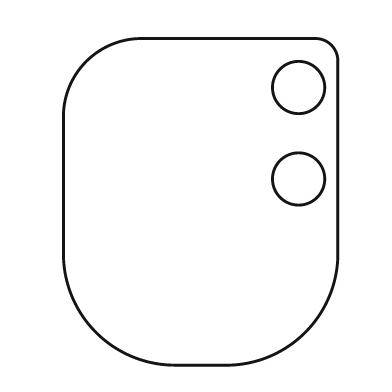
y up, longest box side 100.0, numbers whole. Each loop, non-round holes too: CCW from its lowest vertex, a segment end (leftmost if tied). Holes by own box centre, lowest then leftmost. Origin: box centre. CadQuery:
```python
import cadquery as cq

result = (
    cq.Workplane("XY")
    .moveTo(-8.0, -50.0)
    .lineTo(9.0, -50.0)
    .threePointArc((32.0, -40.0), (42.0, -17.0))
    .lineTo(42.0, 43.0)
    .threePointArc((40.0, 48.0), (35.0, 50.0))
    .lineTo(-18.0, 50.0)
    .threePointArc((-35.0, 43.0), (-42.0, 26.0))
    .lineTo(-42.0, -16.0)
    .threePointArc((-32.0, -40.0), (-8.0, -50.0))
    .close()
    .moveTo(30.0, 7.0)
    .circle(8.0)
    .moveTo(30.0, 35.0)
    .circle(8.0)
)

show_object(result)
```